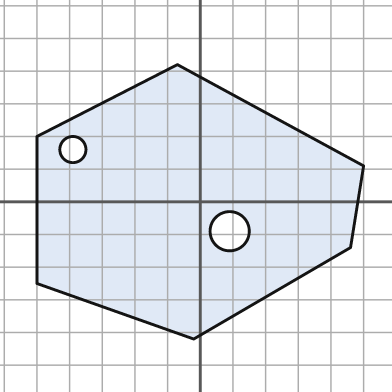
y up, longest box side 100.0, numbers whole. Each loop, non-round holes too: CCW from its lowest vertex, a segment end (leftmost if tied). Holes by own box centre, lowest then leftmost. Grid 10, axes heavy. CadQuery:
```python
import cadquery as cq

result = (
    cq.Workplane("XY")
    .moveTo(-2.0, -42.0)
    .lineTo(46.0, -14.0)
    .lineTo(50.0, 11.0)
    .lineTo(-7.0, 42.0)
    .lineTo(-50.0, 20.0)
    .lineTo(-50.0, -25.0)
    .close()
    .moveTo(9.0, -9.0)
    .circle(6.0)
    .moveTo(-39.0, 16.0)
    .circle(4.0)
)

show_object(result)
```